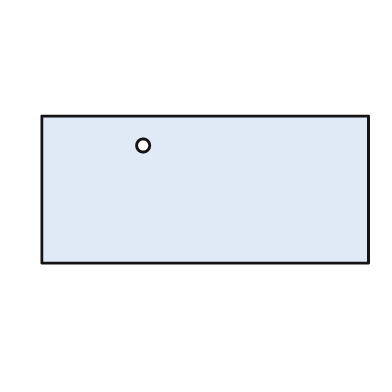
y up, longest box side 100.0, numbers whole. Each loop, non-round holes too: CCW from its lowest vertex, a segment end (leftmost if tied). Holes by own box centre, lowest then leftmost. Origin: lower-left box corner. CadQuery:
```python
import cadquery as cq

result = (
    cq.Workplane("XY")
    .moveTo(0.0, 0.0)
    .lineTo(100.0, 0.0)
    .lineTo(100.0, 45.0)
    .lineTo(0.0, 45.0)
    .close()
    .moveTo(31.0, 36.0)
    .circle(2.0)
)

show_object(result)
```